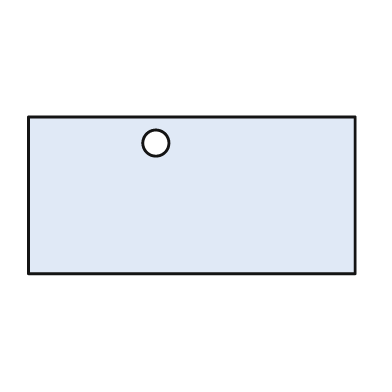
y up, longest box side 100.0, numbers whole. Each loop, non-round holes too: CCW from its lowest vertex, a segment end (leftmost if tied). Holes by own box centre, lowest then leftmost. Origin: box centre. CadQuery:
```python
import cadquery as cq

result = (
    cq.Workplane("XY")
    .moveTo(-50.0, -24.0)
    .lineTo(50.0, -24.0)
    .lineTo(50.0, 24.0)
    .lineTo(-50.0, 24.0)
    .close()
    .moveTo(-11.0, 16.0)
    .circle(4.0)
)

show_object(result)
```